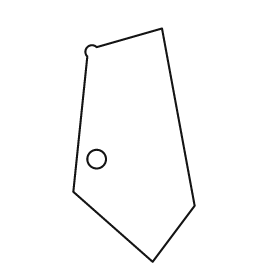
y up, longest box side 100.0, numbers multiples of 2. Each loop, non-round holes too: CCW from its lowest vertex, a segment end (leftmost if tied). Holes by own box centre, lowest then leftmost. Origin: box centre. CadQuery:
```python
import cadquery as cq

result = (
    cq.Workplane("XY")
    .moveTo(8.0, -50.0)
    .lineTo(26.0, -26.0)
    .lineTo(12.0, 50.0)
    .lineTo(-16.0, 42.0)
    .threePointArc((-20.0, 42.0), (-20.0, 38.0))
    .lineTo(-26.0, -20.0)
    .close()
    .moveTo(-16.0, -6.0)
    .circle(4.0)
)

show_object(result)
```